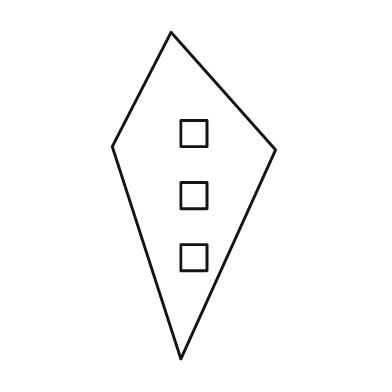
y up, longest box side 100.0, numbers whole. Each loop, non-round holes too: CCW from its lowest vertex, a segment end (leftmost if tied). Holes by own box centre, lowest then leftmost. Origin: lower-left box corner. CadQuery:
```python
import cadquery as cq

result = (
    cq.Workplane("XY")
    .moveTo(21.0, 0.0)
    .lineTo(50.0, 64.0)
    .lineTo(18.0, 100.0)
    .lineTo(0.0, 65.0)
    .close()
    .moveTo(21.0, 27.0)
    .lineTo(29.0, 27.0)
    .lineTo(29.0, 35.0)
    .lineTo(21.0, 35.0)
    .close()
    .moveTo(21.0, 46.0)
    .lineTo(29.0, 46.0)
    .lineTo(29.0, 54.0)
    .lineTo(21.0, 54.0)
    .close()
    .moveTo(21.0, 65.0)
    .lineTo(29.0, 65.0)
    .lineTo(29.0, 73.0)
    .lineTo(21.0, 73.0)
    .close()
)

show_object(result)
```